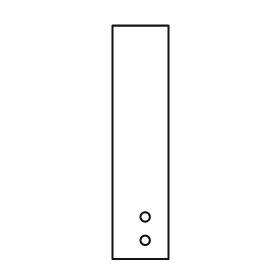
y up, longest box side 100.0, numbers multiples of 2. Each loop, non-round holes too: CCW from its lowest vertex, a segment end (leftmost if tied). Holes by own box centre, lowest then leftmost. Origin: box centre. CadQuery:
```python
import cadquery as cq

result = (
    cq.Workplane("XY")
    .moveTo(-12.0, -50.0)
    .lineTo(12.0, -50.0)
    .lineTo(12.0, 50.0)
    .lineTo(-12.0, 50.0)
    .close()
    .moveTo(2.0, -42.0)
    .circle(2.0)
    .moveTo(2.0, -32.0)
    .circle(2.0)
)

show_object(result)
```